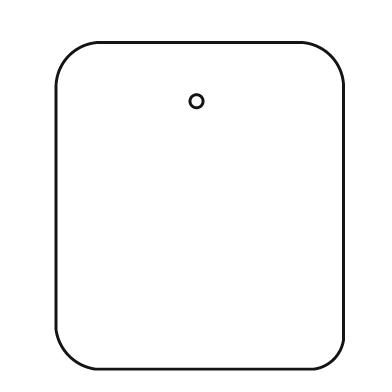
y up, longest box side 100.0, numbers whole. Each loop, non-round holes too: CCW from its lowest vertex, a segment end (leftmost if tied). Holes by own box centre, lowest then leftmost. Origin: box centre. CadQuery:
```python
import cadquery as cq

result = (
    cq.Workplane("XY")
    .moveTo(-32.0, -50.0)
    .lineTo(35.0, -50.0)
    .threePointArc((41.0, -47.0), (44.0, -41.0))
    .lineTo(44.0, 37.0)
    .threePointArc((40.0, 46.0), (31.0, 50.0))
    .lineTo(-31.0, 50.0)
    .threePointArc((-40.0, 46.0), (-44.0, 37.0))
    .lineTo(-44.0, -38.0)
    .threePointArc((-40.0, -46.0), (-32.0, -50.0))
    .close()
    .moveTo(-1.0, 32.0)
    .circle(2.0)
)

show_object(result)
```